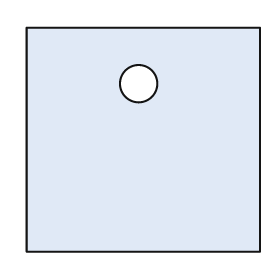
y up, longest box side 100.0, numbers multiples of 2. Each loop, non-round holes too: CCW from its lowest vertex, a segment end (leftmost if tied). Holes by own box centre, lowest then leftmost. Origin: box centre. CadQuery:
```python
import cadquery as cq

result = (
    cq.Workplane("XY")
    .moveTo(-50.0, -48.0)
    .lineTo(50.0, -48.0)
    .lineTo(50.0, 48.0)
    .lineTo(-50.0, 48.0)
    .close()
    .moveTo(-2.0, 24.0)
    .circle(8.0)
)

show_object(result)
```